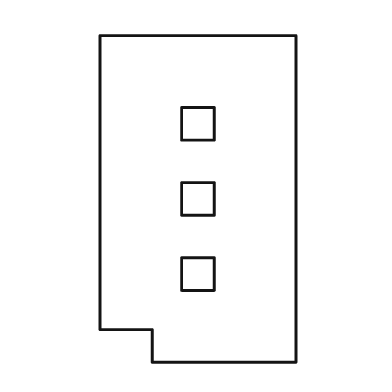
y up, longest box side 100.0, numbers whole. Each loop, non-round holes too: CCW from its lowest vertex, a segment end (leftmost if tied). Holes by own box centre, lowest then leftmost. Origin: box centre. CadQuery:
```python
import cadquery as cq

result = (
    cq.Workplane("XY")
    .moveTo(-14.0, -50.0)
    .lineTo(30.0, -50.0)
    .lineTo(30.0, 50.0)
    .lineTo(-30.0, 50.0)
    .lineTo(-30.0, -40.0)
    .lineTo(-14.0, -40.0)
    .close()
    .moveTo(-5.0, -28.0)
    .lineTo(5.0, -28.0)
    .lineTo(5.0, -18.0)
    .lineTo(-5.0, -18.0)
    .close()
    .moveTo(-5.0, -5.0)
    .lineTo(5.0, -5.0)
    .lineTo(5.0, 5.0)
    .lineTo(-5.0, 5.0)
    .close()
    .moveTo(-5.0, 18.0)
    .lineTo(5.0, 18.0)
    .lineTo(5.0, 28.0)
    .lineTo(-5.0, 28.0)
    .close()
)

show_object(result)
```